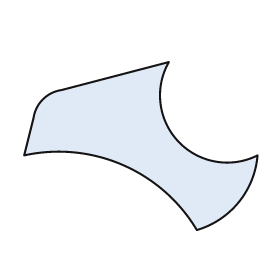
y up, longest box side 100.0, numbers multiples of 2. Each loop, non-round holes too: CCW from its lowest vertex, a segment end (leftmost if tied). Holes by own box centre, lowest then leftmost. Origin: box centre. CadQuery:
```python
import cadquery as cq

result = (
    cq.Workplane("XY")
    .moveTo(24.0, -36.0)
    .threePointArc((42.0, -24.0), (50.0, -4.0))
    .threePointArc((16.0, 2.0), (12.0, 36.0))
    .lineTo(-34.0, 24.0)
    .threePointArc((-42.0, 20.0), (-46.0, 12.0))
    .lineTo(-50.0, -4.0)
    .threePointArc((-8.0, -8.0), (24.0, -36.0))
    .close()
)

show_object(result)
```